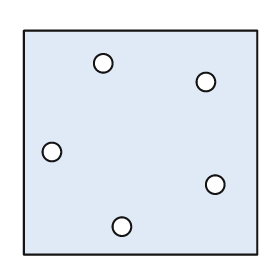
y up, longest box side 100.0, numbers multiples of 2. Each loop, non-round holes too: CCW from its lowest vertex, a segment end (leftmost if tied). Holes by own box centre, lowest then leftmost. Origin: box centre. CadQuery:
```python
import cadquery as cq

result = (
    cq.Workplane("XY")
    .moveTo(-50.0, -48.0)
    .lineTo(50.0, -48.0)
    .lineTo(50.0, 48.0)
    .lineTo(-50.0, 48.0)
    .close()
    .moveTo(-8.0, -36.0)
    .circle(4.0)
    .moveTo(32.0, -18.0)
    .circle(4.0)
    .moveTo(-38.0, -4.0)
    .circle(4.0)
    .moveTo(28.0, 26.0)
    .circle(4.0)
    .moveTo(-16.0, 34.0)
    .circle(4.0)
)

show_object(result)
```